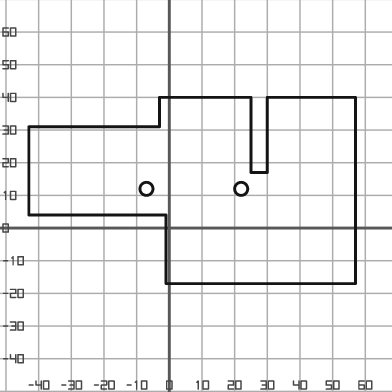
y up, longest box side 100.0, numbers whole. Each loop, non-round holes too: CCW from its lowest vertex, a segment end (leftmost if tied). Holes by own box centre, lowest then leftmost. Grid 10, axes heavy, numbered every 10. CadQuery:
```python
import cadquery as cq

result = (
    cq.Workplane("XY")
    .moveTo(-1.0, -17.0)
    .lineTo(57.0, -17.0)
    .lineTo(57.0, 40.0)
    .lineTo(30.0, 40.0)
    .lineTo(30.0, 17.0)
    .lineTo(25.0, 17.0)
    .lineTo(25.0, 40.0)
    .lineTo(-3.0, 40.0)
    .lineTo(-3.0, 31.0)
    .lineTo(-43.0, 31.0)
    .lineTo(-43.0, 4.0)
    .lineTo(-1.0, 4.0)
    .close()
    .moveTo(-7.0, 12.0)
    .circle(2.0)
    .moveTo(22.0, 12.0)
    .circle(2.0)
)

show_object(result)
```